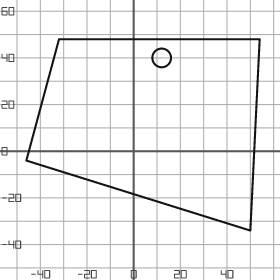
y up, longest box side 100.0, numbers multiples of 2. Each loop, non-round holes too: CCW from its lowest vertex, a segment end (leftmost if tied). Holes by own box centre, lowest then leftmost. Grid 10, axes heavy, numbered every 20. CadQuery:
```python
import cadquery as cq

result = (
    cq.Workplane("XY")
    .moveTo(50.0, -34.0)
    .lineTo(54.0, 48.0)
    .lineTo(-32.0, 48.0)
    .lineTo(-46.0, -4.0)
    .close()
    .moveTo(12.0, 40.0)
    .circle(4.0)
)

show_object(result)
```